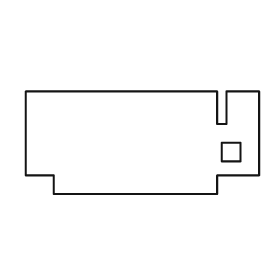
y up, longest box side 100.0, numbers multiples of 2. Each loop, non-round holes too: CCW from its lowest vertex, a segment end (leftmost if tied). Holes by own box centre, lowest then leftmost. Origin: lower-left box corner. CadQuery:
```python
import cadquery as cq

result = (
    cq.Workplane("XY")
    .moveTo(12.0, 0.0)
    .lineTo(82.0, 0.0)
    .lineTo(82.0, 8.0)
    .lineTo(100.0, 8.0)
    .lineTo(100.0, 44.0)
    .lineTo(86.0, 44.0)
    .lineTo(86.0, 30.0)
    .lineTo(82.0, 30.0)
    .lineTo(82.0, 44.0)
    .lineTo(0.0, 44.0)
    .lineTo(0.0, 8.0)
    .lineTo(12.0, 8.0)
    .close()
    .moveTo(84.0, 14.0)
    .lineTo(92.0, 14.0)
    .lineTo(92.0, 22.0)
    .lineTo(84.0, 22.0)
    .close()
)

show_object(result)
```